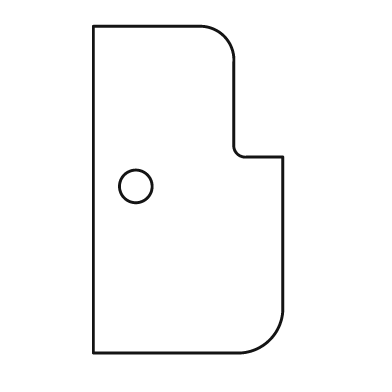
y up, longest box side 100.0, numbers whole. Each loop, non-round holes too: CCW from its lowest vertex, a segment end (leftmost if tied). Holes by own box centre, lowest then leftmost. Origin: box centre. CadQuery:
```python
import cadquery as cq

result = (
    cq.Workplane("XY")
    .moveTo(-29.0, -50.0)
    .lineTo(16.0, -50.0)
    .threePointArc((25.0, -46.0), (29.0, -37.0))
    .lineTo(29.0, 10.0)
    .lineTo(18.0, 10.0)
    .threePointArc((15.0, 11.0), (14.0, 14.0))
    .lineTo(14.0, 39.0)
    .threePointArc((11.0, 47.0), (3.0, 50.0))
    .lineTo(-29.0, 50.0)
    .close()
    .moveTo(-16.0, 1.0)
    .circle(5.0)
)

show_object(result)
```